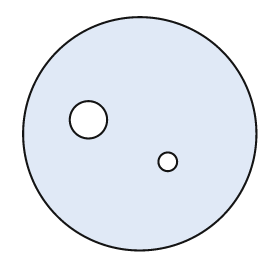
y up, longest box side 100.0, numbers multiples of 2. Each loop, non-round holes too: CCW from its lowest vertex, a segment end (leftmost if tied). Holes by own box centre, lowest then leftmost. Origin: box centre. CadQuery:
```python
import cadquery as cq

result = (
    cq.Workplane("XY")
    .moveTo(0.0, 0.0)
    .circle(50.0)
    .moveTo(12.0, -12.0)
    .circle(4.0)
    .moveTo(-22.0, 6.0)
    .circle(8.0)
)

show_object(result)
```